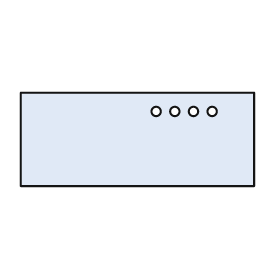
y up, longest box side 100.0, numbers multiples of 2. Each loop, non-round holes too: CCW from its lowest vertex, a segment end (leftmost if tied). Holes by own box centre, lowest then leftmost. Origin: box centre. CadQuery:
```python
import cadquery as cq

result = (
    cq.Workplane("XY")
    .moveTo(-50.0, -20.0)
    .lineTo(50.0, -20.0)
    .lineTo(50.0, 20.0)
    .lineTo(-50.0, 20.0)
    .close()
    .moveTo(8.0, 12.0)
    .circle(2.0)
    .moveTo(16.0, 12.0)
    .circle(2.0)
    .moveTo(24.0, 12.0)
    .circle(2.0)
    .moveTo(32.0, 12.0)
    .circle(2.0)
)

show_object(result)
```